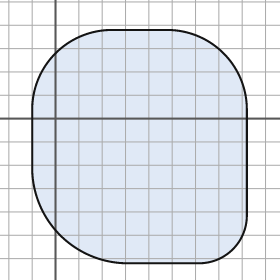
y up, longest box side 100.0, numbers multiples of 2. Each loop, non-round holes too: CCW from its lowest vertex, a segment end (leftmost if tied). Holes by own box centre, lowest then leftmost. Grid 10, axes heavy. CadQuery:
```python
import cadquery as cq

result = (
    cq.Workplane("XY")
    .moveTo(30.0, -62.0)
    .lineTo(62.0, -62.0)
    .threePointArc((76.0, -56.0), (82.0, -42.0))
    .lineTo(82.0, 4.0)
    .threePointArc((72.0, 28.0), (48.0, 38.0))
    .lineTo(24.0, 38.0)
    .threePointArc((0.0, 28.0), (-10.0, 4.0))
    .lineTo(-10.0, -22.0)
    .threePointArc((2.0, -50.0), (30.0, -62.0))
    .close()
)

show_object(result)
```